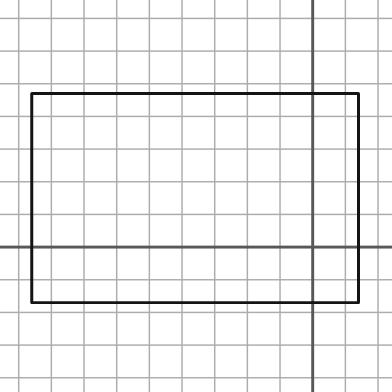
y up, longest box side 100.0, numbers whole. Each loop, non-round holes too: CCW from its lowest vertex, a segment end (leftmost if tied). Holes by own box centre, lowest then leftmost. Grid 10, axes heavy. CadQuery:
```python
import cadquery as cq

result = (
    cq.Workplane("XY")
    .moveTo(-86.0, -17.0)
    .lineTo(14.0, -17.0)
    .lineTo(14.0, 47.0)
    .lineTo(-86.0, 47.0)
    .close()
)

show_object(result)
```